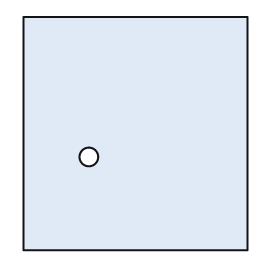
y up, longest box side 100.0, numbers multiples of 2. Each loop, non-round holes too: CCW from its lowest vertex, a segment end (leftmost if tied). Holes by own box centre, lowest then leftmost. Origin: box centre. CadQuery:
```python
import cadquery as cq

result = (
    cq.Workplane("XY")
    .moveTo(-48.0, -50.0)
    .lineTo(48.0, -50.0)
    .lineTo(48.0, 50.0)
    .lineTo(-48.0, 50.0)
    .close()
    .moveTo(-20.0, -10.0)
    .circle(4.0)
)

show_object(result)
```